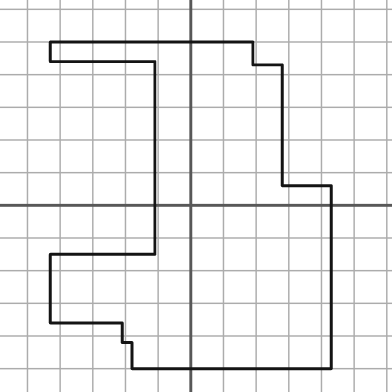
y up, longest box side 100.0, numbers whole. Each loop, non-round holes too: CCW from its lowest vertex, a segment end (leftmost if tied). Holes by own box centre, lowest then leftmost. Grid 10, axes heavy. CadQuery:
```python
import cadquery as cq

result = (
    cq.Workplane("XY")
    .moveTo(-18.0, -50.0)
    .lineTo(43.0, -50.0)
    .lineTo(43.0, 6.0)
    .lineTo(28.0, 6.0)
    .lineTo(28.0, 43.0)
    .lineTo(19.0, 43.0)
    .lineTo(19.0, 50.0)
    .lineTo(-43.0, 50.0)
    .lineTo(-43.0, 44.0)
    .lineTo(-11.0, 44.0)
    .lineTo(-11.0, -15.0)
    .lineTo(-43.0, -15.0)
    .lineTo(-43.0, -36.0)
    .lineTo(-21.0, -36.0)
    .lineTo(-21.0, -42.0)
    .lineTo(-18.0, -42.0)
    .close()
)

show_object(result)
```